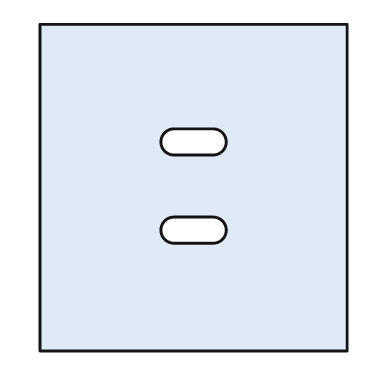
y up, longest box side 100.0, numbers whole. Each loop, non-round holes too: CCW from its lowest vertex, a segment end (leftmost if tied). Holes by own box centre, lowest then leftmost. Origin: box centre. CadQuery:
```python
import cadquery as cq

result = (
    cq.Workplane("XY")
    .moveTo(-47.0, -50.0)
    .lineTo(47.0, -50.0)
    .lineTo(47.0, 50.0)
    .lineTo(-47.0, 50.0)
    .close()
    .moveTo(-6.0, -17.0)
    .lineTo(6.0, -17.0)
    .threePointArc((10.0, -13.0), (6.0, -9.0))
    .lineTo(-6.0, -9.0)
    .threePointArc((-10.0, -13.0), (-6.0, -17.0))
    .close()
    .moveTo(-6.0, 10.0)
    .lineTo(6.0, 10.0)
    .threePointArc((10.0, 14.0), (6.0, 18.0))
    .lineTo(-6.0, 18.0)
    .threePointArc((-10.0, 14.0), (-6.0, 10.0))
    .close()
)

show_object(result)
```